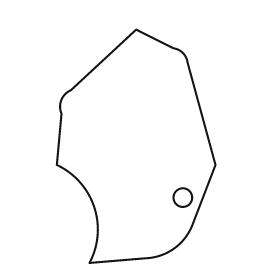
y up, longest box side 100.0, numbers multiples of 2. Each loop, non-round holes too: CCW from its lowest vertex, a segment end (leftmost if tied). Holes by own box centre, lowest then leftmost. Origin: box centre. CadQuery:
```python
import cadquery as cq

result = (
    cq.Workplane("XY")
    .moveTo(-20.0, -50.0)
    .lineTo(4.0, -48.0)
    .threePointArc((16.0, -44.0), (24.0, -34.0))
    .lineTo(34.0, -8.0)
    .lineTo(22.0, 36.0)
    .threePointArc((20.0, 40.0), (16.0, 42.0))
    .lineTo(0.0, 50.0)
    .lineTo(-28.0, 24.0)
    .threePointArc((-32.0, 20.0), (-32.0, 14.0))
    .lineTo(-34.0, -8.0)
    .threePointArc((-18.0, -26.0), (-20.0, -50.0))
    .close()
    .moveTo(20.0, -22.0)
    .circle(4.0)
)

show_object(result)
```